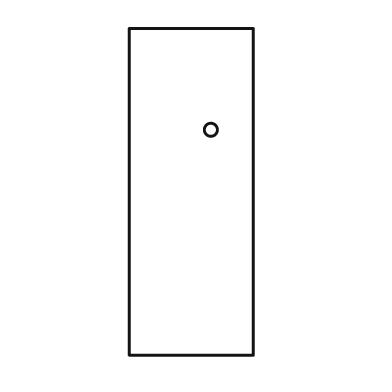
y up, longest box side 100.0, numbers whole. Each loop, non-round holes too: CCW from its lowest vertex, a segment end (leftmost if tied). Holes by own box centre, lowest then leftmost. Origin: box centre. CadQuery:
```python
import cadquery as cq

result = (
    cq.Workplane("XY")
    .moveTo(-19.0, -50.0)
    .lineTo(19.0, -50.0)
    .lineTo(19.0, 50.0)
    .lineTo(-19.0, 50.0)
    .close()
    .moveTo(6.0, 19.0)
    .circle(2.0)
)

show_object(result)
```